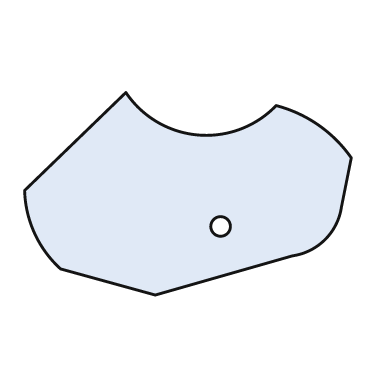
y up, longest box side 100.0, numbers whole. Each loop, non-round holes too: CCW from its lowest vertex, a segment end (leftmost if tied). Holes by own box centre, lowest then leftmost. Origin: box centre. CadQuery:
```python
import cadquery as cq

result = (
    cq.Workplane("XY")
    .moveTo(-10.0, -31.0)
    .lineTo(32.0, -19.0)
    .threePointArc((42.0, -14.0), (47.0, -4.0))
    .lineTo(50.0, 11.0)
    .threePointArc((40.0, 21.0), (27.0, 27.0))
    .threePointArc((3.0, 18.0), (-19.0, 31.0))
    .lineTo(-50.0, 1.0)
    .threePointArc((-47.0, -12.0), (-39.0, -23.0))
    .close()
    .moveTo(10.0, -10.0)
    .circle(3.0)
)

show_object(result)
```